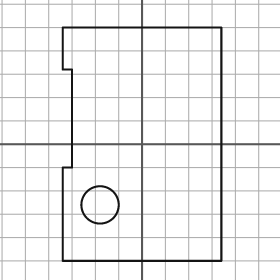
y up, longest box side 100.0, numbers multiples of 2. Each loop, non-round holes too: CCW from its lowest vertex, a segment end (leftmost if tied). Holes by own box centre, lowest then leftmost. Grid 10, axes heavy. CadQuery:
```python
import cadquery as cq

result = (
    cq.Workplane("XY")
    .moveTo(-34.0, -50.0)
    .lineTo(34.0, -50.0)
    .lineTo(34.0, 50.0)
    .lineTo(-34.0, 50.0)
    .lineTo(-34.0, 32.0)
    .lineTo(-30.0, 32.0)
    .lineTo(-30.0, -10.0)
    .lineTo(-34.0, -10.0)
    .close()
    .moveTo(-18.0, -26.0)
    .circle(8.0)
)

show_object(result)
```